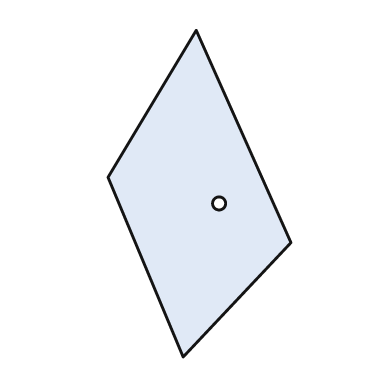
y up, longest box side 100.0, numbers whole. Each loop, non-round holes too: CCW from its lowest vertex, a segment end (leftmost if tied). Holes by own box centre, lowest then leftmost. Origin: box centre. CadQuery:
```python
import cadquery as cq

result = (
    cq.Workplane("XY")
    .moveTo(-5.0, -50.0)
    .lineTo(28.0, -15.0)
    .lineTo(-1.0, 50.0)
    .lineTo(-28.0, 5.0)
    .close()
    .moveTo(6.0, -3.0)
    .circle(2.0)
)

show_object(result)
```